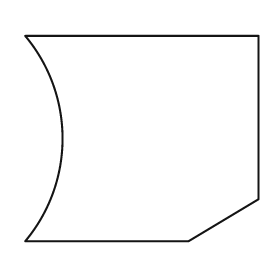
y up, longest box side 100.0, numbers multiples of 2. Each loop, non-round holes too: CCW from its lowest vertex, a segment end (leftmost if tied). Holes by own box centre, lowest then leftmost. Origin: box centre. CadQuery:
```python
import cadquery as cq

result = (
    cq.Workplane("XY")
    .moveTo(-50.0, -44.0)
    .lineTo(20.0, -44.0)
    .lineTo(50.0, -26.0)
    .lineTo(50.0, 44.0)
    .lineTo(-50.0, 44.0)
    .threePointArc((-34.0, 0.0), (-50.0, -44.0))
    .close()
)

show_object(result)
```